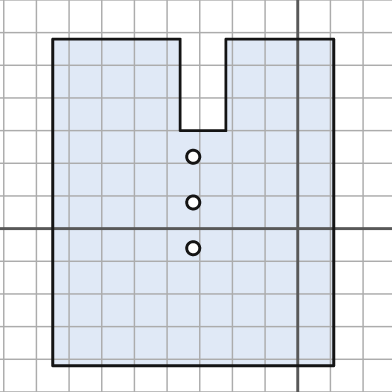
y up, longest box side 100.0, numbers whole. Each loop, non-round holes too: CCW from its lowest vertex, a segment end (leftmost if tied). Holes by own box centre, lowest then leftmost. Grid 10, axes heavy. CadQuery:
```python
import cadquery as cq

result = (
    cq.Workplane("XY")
    .moveTo(-75.0, -42.0)
    .lineTo(11.0, -42.0)
    .lineTo(11.0, 58.0)
    .lineTo(-22.0, 58.0)
    .lineTo(-22.0, 30.0)
    .lineTo(-36.0, 30.0)
    .lineTo(-36.0, 58.0)
    .lineTo(-75.0, 58.0)
    .close()
    .moveTo(-32.0, -6.0)
    .circle(2.0)
    .moveTo(-32.0, 8.0)
    .circle(2.0)
    .moveTo(-32.0, 22.0)
    .circle(2.0)
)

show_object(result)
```